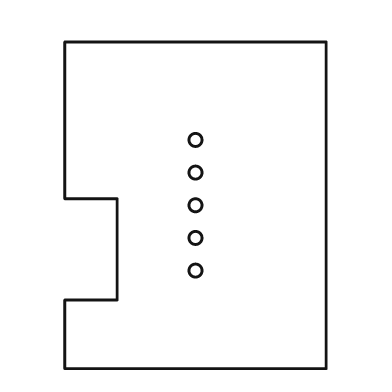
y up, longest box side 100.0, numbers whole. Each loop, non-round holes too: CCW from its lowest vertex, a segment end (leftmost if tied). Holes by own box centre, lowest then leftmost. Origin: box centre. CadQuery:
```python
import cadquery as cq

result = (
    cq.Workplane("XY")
    .moveTo(-40.0, -50.0)
    .lineTo(40.0, -50.0)
    .lineTo(40.0, 50.0)
    .lineTo(-40.0, 50.0)
    .lineTo(-40.0, 2.0)
    .lineTo(-24.0, 2.0)
    .lineTo(-24.0, -29.0)
    .lineTo(-40.0, -29.0)
    .close()
    .moveTo(0.0, -20.0)
    .circle(2.0)
    .moveTo(0.0, -10.0)
    .circle(2.0)
    .moveTo(0.0, 0.0)
    .circle(2.0)
    .moveTo(0.0, 10.0)
    .circle(2.0)
    .moveTo(0.0, 20.0)
    .circle(2.0)
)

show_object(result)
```